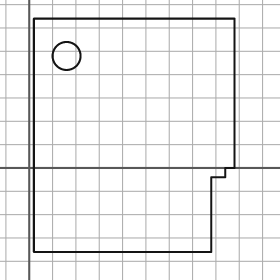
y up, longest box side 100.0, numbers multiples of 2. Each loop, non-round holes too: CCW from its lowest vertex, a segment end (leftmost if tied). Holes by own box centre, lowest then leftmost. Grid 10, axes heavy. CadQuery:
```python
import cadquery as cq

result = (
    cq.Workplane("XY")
    .moveTo(2.0, -36.0)
    .lineTo(78.0, -36.0)
    .lineTo(78.0, -4.0)
    .lineTo(84.0, -4.0)
    .lineTo(84.0, 0.0)
    .lineTo(88.0, 0.0)
    .lineTo(88.0, 64.0)
    .lineTo(2.0, 64.0)
    .close()
    .moveTo(16.0, 48.0)
    .circle(6.0)
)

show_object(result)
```